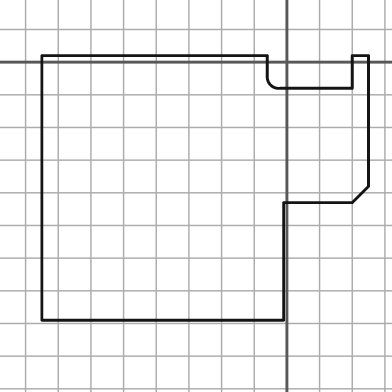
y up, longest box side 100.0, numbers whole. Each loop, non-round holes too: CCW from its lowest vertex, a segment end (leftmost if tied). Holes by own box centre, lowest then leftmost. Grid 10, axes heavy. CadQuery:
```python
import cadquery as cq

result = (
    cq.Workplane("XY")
    .moveTo(-75.0, -79.0)
    .lineTo(-1.0, -79.0)
    .lineTo(-1.0, -43.0)
    .lineTo(20.0, -43.0)
    .lineTo(25.0, -38.0)
    .lineTo(25.0, 2.0)
    .lineTo(20.0, 2.0)
    .lineTo(20.0, -8.0)
    .lineTo(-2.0, -8.0)
    .threePointArc((-5.0, -7.0), (-6.0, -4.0))
    .lineTo(-6.0, 2.0)
    .lineTo(-75.0, 2.0)
    .close()
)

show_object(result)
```